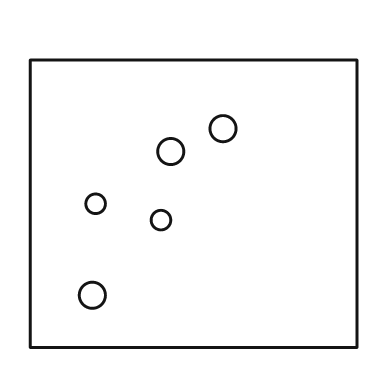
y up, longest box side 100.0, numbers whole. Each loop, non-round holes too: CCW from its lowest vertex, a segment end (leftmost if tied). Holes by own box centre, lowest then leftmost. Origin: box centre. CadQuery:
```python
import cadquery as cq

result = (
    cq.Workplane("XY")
    .moveTo(-50.0, -44.0)
    .lineTo(50.0, -44.0)
    .lineTo(50.0, 44.0)
    .lineTo(-50.0, 44.0)
    .close()
    .moveTo(-31.0, -28.0)
    .circle(4.0)
    .moveTo(-10.0, -5.0)
    .circle(3.0)
    .moveTo(-30.0, 0.0)
    .circle(3.0)
    .moveTo(-7.0, 16.0)
    .circle(4.0)
    .moveTo(9.0, 23.0)
    .circle(4.0)
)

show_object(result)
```